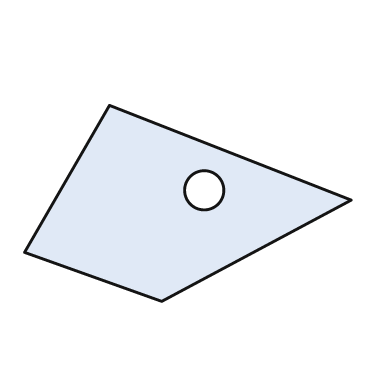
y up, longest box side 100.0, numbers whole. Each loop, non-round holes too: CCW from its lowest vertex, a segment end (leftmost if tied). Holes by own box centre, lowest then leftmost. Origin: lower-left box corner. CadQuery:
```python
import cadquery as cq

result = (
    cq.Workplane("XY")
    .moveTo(42.0, 0.0)
    .lineTo(100.0, 31.0)
    .lineTo(26.0, 60.0)
    .lineTo(0.0, 15.0)
    .close()
    .moveTo(55.0, 34.0)
    .circle(6.0)
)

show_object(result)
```